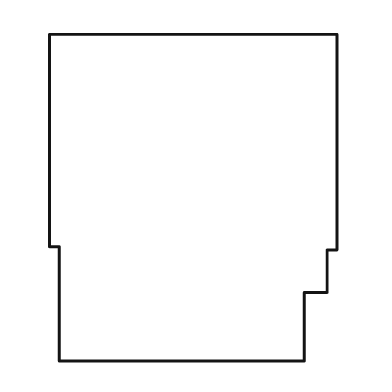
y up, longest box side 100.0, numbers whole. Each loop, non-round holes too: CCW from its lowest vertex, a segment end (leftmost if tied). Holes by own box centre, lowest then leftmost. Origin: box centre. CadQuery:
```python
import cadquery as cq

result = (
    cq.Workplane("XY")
    .moveTo(-41.0, -50.0)
    .lineTo(34.0, -50.0)
    .lineTo(34.0, -29.0)
    .lineTo(41.0, -29.0)
    .lineTo(41.0, -16.0)
    .lineTo(44.0, -16.0)
    .lineTo(44.0, 50.0)
    .lineTo(-44.0, 50.0)
    .lineTo(-44.0, -15.0)
    .lineTo(-41.0, -15.0)
    .close()
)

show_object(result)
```